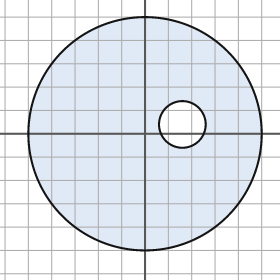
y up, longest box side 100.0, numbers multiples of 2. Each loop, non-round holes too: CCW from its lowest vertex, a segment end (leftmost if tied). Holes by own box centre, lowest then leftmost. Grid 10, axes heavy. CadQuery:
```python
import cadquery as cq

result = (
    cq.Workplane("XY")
    .moveTo(0.0, 0.0)
    .circle(50.0)
    .moveTo(16.0, 4.0)
    .circle(10.0)
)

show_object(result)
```